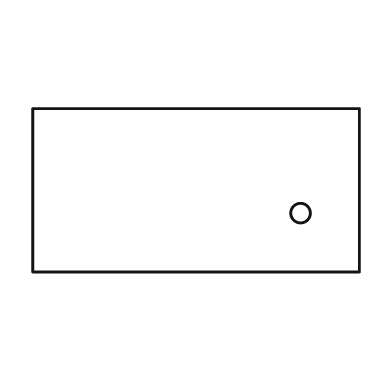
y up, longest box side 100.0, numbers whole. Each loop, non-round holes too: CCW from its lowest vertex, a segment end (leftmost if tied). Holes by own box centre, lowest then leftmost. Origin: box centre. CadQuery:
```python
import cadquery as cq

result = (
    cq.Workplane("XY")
    .moveTo(-50.0, -25.0)
    .lineTo(50.0, -25.0)
    .lineTo(50.0, 25.0)
    .lineTo(-50.0, 25.0)
    .close()
    .moveTo(32.0, -7.0)
    .circle(3.0)
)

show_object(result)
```